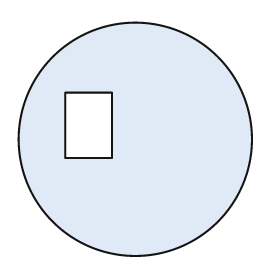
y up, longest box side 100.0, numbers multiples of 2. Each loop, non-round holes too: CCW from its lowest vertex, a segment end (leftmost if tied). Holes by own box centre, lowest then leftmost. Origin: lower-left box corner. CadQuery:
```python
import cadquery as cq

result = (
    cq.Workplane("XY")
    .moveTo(50.0, 50.0)
    .circle(50.0)
    .moveTo(20.0, 42.0)
    .lineTo(40.0, 42.0)
    .lineTo(40.0, 70.0)
    .lineTo(20.0, 70.0)
    .close()
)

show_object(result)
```